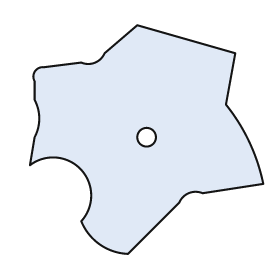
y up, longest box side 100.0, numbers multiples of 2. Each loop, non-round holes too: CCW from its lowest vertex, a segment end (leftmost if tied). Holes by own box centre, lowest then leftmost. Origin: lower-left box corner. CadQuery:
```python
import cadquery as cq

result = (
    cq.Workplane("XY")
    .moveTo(42.0, 0.0)
    .lineTo(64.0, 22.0)
    .threePointArc((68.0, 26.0), (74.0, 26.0))
    .lineTo(100.0, 30.0)
    .threePointArc((94.0, 48.0), (84.0, 64.0))
    .lineTo(88.0, 86.0)
    .lineTo(46.0, 98.0)
    .lineTo(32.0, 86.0)
    .threePointArc((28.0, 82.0), (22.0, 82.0))
    .lineTo(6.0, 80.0)
    .threePointArc((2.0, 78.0), (2.0, 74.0))
    .lineTo(2.0, 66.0)
    .threePointArc((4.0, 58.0), (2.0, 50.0))
    .lineTo(0.0, 38.0)
    .threePointArc((22.0, 36.0), (22.0, 14.0))
    .threePointArc((30.0, 4.0), (42.0, 0.0))
    .close()
    .moveTo(50.0, 50.0)
    .circle(4.0)
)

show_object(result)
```